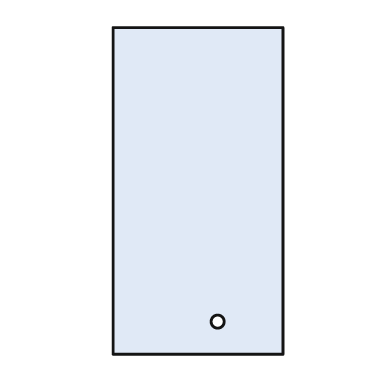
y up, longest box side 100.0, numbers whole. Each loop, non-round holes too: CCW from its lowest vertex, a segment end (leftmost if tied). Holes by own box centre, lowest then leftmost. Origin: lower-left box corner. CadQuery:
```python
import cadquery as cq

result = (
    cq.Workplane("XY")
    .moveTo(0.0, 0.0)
    .lineTo(52.0, 0.0)
    .lineTo(52.0, 100.0)
    .lineTo(0.0, 100.0)
    .close()
    .moveTo(32.0, 10.0)
    .circle(2.0)
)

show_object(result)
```